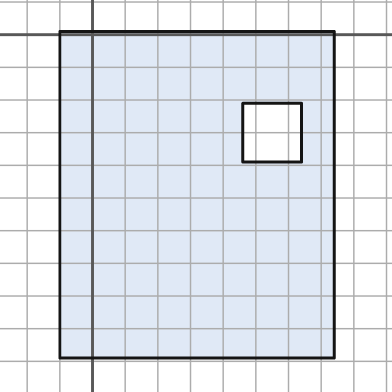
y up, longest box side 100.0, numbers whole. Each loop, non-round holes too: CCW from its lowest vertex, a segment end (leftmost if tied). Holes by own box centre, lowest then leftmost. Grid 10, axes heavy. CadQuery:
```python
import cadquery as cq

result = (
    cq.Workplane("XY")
    .moveTo(-10.0, -99.0)
    .lineTo(74.0, -99.0)
    .lineTo(74.0, 1.0)
    .lineTo(-10.0, 1.0)
    .close()
    .moveTo(46.0, -39.0)
    .lineTo(64.0, -39.0)
    .lineTo(64.0, -21.0)
    .lineTo(46.0, -21.0)
    .close()
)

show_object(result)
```